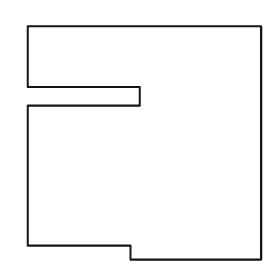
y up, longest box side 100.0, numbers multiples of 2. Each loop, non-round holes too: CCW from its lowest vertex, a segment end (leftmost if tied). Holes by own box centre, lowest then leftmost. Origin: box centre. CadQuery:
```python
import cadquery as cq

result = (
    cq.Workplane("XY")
    .moveTo(-6.0, -50.0)
    .lineTo(50.0, -50.0)
    .lineTo(50.0, 50.0)
    .lineTo(-50.0, 50.0)
    .lineTo(-50.0, 24.0)
    .lineTo(-2.0, 24.0)
    .lineTo(-2.0, 16.0)
    .lineTo(-50.0, 16.0)
    .lineTo(-50.0, -44.0)
    .lineTo(-6.0, -44.0)
    .close()
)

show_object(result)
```